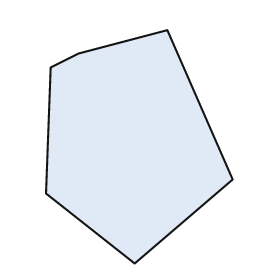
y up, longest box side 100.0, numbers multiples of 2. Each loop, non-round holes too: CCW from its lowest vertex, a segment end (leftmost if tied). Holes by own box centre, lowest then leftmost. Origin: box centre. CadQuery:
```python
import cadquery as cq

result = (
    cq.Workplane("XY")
    .moveTo(-2.0, -50.0)
    .lineTo(40.0, -14.0)
    .lineTo(12.0, 50.0)
    .lineTo(-26.0, 40.0)
    .lineTo(-38.0, 34.0)
    .lineTo(-40.0, -20.0)
    .close()
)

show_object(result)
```